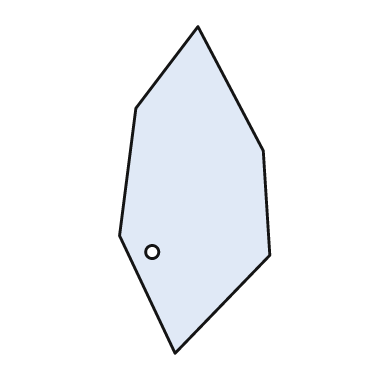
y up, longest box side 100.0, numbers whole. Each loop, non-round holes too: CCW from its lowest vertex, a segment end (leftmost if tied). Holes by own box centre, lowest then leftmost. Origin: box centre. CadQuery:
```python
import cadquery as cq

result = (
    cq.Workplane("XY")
    .moveTo(-6.0, -50.0)
    .lineTo(23.0, -20.0)
    .lineTo(21.0, 12.0)
    .lineTo(1.0, 50.0)
    .lineTo(-18.0, 25.0)
    .lineTo(-23.0, -14.0)
    .close()
    .moveTo(-13.0, -19.0)
    .circle(2.0)
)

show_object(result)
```